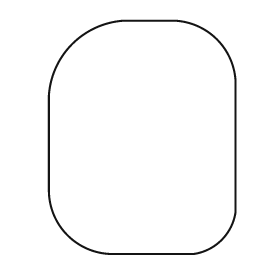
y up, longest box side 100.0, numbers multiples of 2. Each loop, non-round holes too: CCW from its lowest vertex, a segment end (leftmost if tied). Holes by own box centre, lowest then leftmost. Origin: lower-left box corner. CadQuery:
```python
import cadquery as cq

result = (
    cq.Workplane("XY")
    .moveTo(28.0, 0.0)
    .lineTo(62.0, 0.0)
    .threePointArc((74.0, 6.0), (80.0, 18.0))
    .lineTo(80.0, 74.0)
    .threePointArc((72.0, 92.0), (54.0, 100.0))
    .lineTo(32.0, 100.0)
    .threePointArc((10.0, 90.0), (0.0, 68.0))
    .lineTo(0.0, 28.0)
    .threePointArc((8.0, 8.0), (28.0, 0.0))
    .close()
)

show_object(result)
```